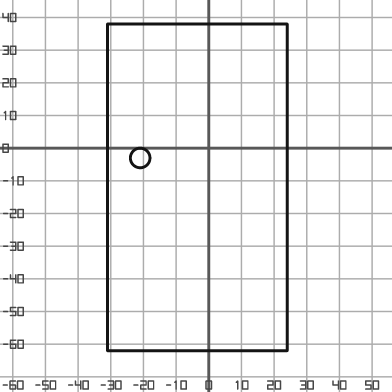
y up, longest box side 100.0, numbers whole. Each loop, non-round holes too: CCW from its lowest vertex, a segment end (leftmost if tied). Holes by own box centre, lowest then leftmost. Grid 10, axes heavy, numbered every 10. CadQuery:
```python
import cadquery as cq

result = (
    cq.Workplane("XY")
    .moveTo(-31.0, -62.0)
    .lineTo(24.0, -62.0)
    .lineTo(24.0, 38.0)
    .lineTo(-31.0, 38.0)
    .close()
    .moveTo(-21.0, -3.0)
    .circle(3.0)
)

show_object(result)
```